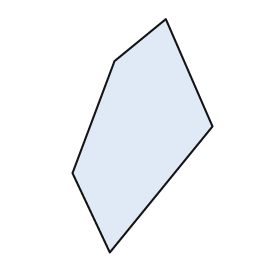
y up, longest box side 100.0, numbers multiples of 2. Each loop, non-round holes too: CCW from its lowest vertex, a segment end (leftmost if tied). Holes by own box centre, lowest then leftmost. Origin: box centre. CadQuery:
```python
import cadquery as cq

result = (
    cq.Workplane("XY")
    .moveTo(-14.0, -50.0)
    .lineTo(30.0, 4.0)
    .lineTo(10.0, 50.0)
    .lineTo(-12.0, 32.0)
    .lineTo(-30.0, -16.0)
    .close()
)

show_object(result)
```